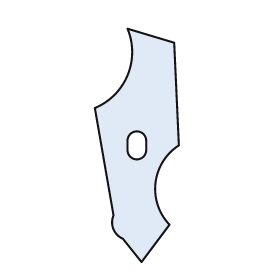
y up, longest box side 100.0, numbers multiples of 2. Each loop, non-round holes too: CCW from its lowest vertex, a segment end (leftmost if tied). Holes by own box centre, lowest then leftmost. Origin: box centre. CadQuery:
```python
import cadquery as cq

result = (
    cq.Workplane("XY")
    .moveTo(2.0, -50.0)
    .lineTo(14.0, -34.0)
    .threePointArc((8.0, -16.0), (18.0, 0.0))
    .lineTo(16.0, 44.0)
    .lineTo(-4.0, 50.0)
    .threePointArc((-4.0, 30.0), (-18.0, 16.0))
    .lineTo(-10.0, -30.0)
    .threePointArc((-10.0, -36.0), (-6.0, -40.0))
    .close()
    .moveTo(-4.0, -2.0)
    .threePointArc((0.0, -6.0), (4.0, -2.0))
    .lineTo(4.0, 2.0)
    .threePointArc((0.0, 6.0), (-4.0, 2.0))
    .close()
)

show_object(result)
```